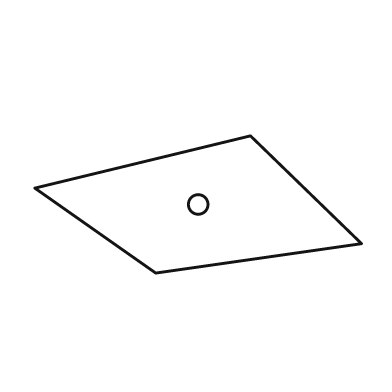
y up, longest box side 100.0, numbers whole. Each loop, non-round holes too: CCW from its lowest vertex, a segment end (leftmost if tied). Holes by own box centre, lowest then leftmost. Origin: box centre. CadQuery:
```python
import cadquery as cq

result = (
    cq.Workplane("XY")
    .moveTo(-13.0, -21.0)
    .lineTo(50.0, -12.0)
    .lineTo(16.0, 21.0)
    .lineTo(-50.0, 5.0)
    .close()
    .moveTo(0.0, 0.0)
    .circle(3.0)
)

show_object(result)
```